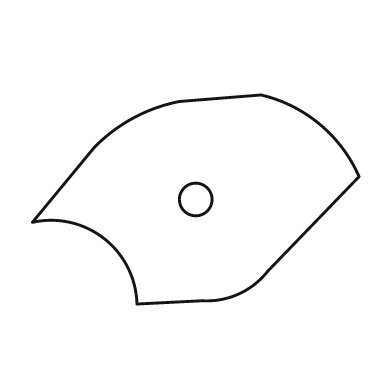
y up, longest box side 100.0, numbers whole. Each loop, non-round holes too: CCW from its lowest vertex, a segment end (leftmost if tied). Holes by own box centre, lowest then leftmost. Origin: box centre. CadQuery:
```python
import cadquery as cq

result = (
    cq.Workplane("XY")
    .moveTo(-18.0, -32.0)
    .lineTo(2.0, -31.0)
    .threePointArc((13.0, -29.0), (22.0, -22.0))
    .lineTo(50.0, 7.0)
    .threePointArc((38.0, 23.0), (20.0, 32.0))
    .lineTo(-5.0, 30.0)
    .threePointArc((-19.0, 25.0), (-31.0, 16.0))
    .lineTo(-50.0, -7.0)
    .threePointArc((-28.0, -12.0), (-18.0, -32.0))
    .close()
    .moveTo(0.0, 0.0)
    .circle(5.0)
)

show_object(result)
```